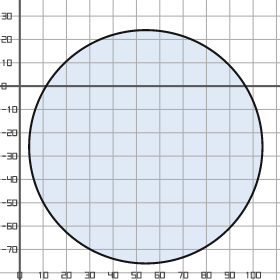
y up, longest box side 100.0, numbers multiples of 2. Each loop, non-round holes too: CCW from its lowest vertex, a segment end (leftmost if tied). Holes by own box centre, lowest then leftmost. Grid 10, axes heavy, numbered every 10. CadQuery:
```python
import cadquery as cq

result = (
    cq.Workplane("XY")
    .moveTo(54.0, -26.0)
    .circle(50.0)
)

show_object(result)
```